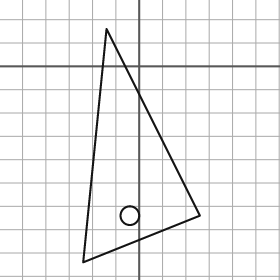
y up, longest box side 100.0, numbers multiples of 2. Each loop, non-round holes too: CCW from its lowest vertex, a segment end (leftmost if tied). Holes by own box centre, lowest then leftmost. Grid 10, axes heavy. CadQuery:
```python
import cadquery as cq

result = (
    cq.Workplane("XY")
    .moveTo(-24.0, -84.0)
    .lineTo(26.0, -64.0)
    .lineTo(-14.0, 16.0)
    .close()
    .moveTo(-4.0, -64.0)
    .circle(4.0)
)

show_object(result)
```